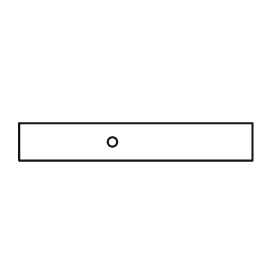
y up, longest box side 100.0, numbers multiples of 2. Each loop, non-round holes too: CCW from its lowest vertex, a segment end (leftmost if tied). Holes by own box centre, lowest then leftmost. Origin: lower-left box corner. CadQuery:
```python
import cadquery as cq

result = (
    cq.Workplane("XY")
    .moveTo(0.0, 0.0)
    .lineTo(100.0, 0.0)
    .lineTo(100.0, 16.0)
    .lineTo(0.0, 16.0)
    .close()
    .moveTo(40.0, 8.0)
    .circle(2.0)
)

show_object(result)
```